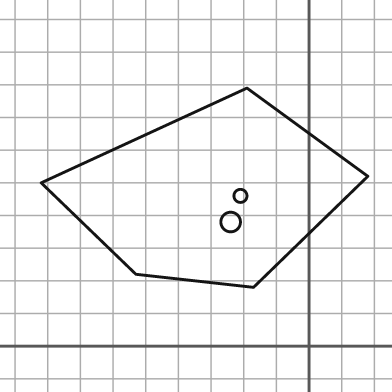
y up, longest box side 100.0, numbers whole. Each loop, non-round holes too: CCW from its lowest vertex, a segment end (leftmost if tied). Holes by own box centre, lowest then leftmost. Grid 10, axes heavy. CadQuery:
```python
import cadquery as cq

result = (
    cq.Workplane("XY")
    .moveTo(-17.0, 18.0)
    .lineTo(18.0, 52.0)
    .lineTo(-19.0, 79.0)
    .lineTo(-82.0, 50.0)
    .lineTo(-53.0, 22.0)
    .close()
    .moveTo(-24.0, 38.0)
    .circle(3.0)
    .moveTo(-21.0, 46.0)
    .circle(2.0)
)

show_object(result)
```